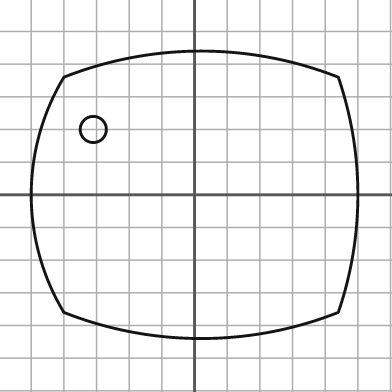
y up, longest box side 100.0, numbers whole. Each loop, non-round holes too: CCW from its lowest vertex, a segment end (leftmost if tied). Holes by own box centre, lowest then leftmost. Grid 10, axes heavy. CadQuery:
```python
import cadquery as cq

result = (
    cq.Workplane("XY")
    .moveTo(-40.0, -36.0)
    .threePointArc((2.0, -44.0), (44.0, -36.0))
    .threePointArc((50.0, 0.0), (44.0, 36.0))
    .threePointArc((2.0, 44.0), (-40.0, 36.0))
    .threePointArc((-50.0, 0.0), (-40.0, -36.0))
    .close()
    .moveTo(-31.0, 20.0)
    .circle(4.0)
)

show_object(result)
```